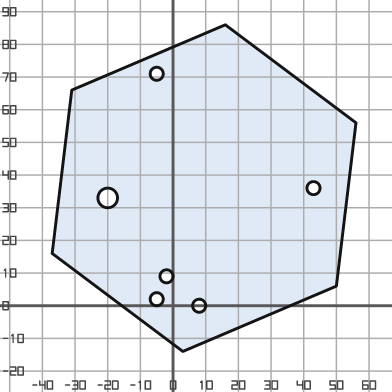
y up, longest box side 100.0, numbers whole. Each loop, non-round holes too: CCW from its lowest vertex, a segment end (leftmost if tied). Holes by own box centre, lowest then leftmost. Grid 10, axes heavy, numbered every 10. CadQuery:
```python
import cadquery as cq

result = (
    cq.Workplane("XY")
    .moveTo(3.0, -14.0)
    .lineTo(50.0, 6.0)
    .lineTo(56.0, 56.0)
    .lineTo(16.0, 86.0)
    .lineTo(-31.0, 66.0)
    .lineTo(-37.0, 16.0)
    .close()
    .moveTo(8.0, 0.0)
    .circle(2.0)
    .moveTo(-5.0, 2.0)
    .circle(2.0)
    .moveTo(-2.0, 9.0)
    .circle(2.0)
    .moveTo(-20.0, 33.0)
    .circle(3.0)
    .moveTo(43.0, 36.0)
    .circle(2.0)
    .moveTo(-5.0, 71.0)
    .circle(2.0)
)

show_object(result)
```